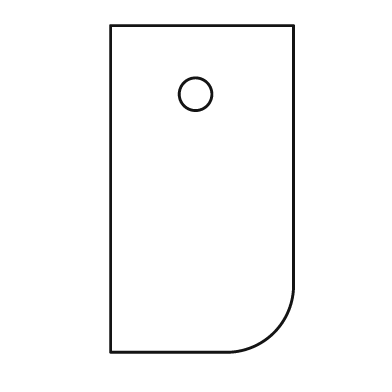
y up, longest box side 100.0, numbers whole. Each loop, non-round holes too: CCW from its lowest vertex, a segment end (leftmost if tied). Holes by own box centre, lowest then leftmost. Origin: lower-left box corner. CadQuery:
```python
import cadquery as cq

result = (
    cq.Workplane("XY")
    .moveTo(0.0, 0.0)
    .lineTo(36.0, 0.0)
    .threePointArc((50.0, 6.0), (56.0, 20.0))
    .lineTo(56.0, 100.0)
    .lineTo(0.0, 100.0)
    .close()
    .moveTo(26.0, 79.0)
    .circle(5.0)
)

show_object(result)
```